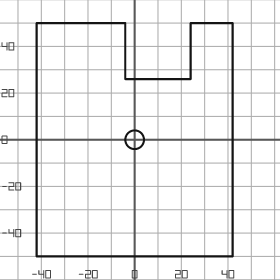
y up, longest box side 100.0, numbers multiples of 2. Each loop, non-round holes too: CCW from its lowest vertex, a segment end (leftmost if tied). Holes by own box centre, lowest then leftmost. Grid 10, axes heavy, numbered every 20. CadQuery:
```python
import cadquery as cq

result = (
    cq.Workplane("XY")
    .moveTo(-42.0, -50.0)
    .lineTo(42.0, -50.0)
    .lineTo(42.0, 50.0)
    .lineTo(24.0, 50.0)
    .lineTo(24.0, 26.0)
    .lineTo(-4.0, 26.0)
    .lineTo(-4.0, 50.0)
    .lineTo(-42.0, 50.0)
    .close()
    .moveTo(0.0, 0.0)
    .circle(4.0)
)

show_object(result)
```